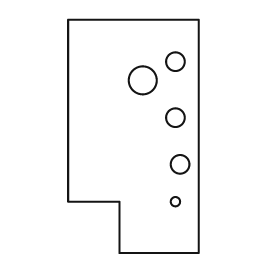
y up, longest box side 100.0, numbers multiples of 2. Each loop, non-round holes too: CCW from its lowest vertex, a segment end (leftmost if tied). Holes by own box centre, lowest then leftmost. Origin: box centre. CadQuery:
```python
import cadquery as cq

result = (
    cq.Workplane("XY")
    .moveTo(-6.0, -50.0)
    .lineTo(28.0, -50.0)
    .lineTo(28.0, 50.0)
    .lineTo(-28.0, 50.0)
    .lineTo(-28.0, -28.0)
    .lineTo(-6.0, -28.0)
    .close()
    .moveTo(18.0, -28.0)
    .circle(2.0)
    .moveTo(20.0, -12.0)
    .circle(4.0)
    .moveTo(18.0, 8.0)
    .circle(4.0)
    .moveTo(4.0, 24.0)
    .circle(6.0)
    .moveTo(18.0, 32.0)
    .circle(4.0)
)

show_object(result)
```